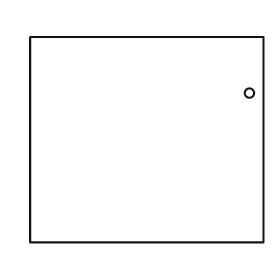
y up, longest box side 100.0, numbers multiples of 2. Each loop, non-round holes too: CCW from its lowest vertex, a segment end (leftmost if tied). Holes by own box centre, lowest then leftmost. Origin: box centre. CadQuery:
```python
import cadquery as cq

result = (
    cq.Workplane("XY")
    .moveTo(-50.0, -44.0)
    .lineTo(50.0, -44.0)
    .lineTo(50.0, 44.0)
    .lineTo(-50.0, 44.0)
    .close()
    .moveTo(44.0, 20.0)
    .circle(2.0)
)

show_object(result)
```